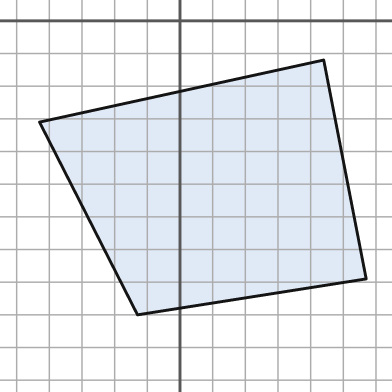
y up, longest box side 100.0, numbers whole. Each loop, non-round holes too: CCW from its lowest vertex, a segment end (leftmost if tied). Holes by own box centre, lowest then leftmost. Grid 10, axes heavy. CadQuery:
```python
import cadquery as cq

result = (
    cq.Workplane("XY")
    .moveTo(-13.0, -90.0)
    .lineTo(57.0, -79.0)
    .lineTo(44.0, -12.0)
    .lineTo(-43.0, -31.0)
    .close()
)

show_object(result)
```